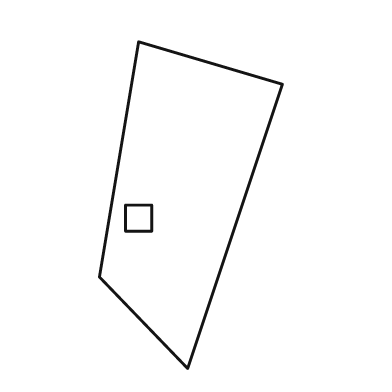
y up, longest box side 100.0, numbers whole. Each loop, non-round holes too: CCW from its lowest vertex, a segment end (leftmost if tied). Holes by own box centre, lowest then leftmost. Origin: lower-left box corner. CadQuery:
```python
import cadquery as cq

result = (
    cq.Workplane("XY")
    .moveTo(27.0, 0.0)
    .lineTo(56.0, 87.0)
    .lineTo(12.0, 100.0)
    .lineTo(0.0, 28.0)
    .close()
    .moveTo(8.0, 42.0)
    .lineTo(16.0, 42.0)
    .lineTo(16.0, 50.0)
    .lineTo(8.0, 50.0)
    .close()
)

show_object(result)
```